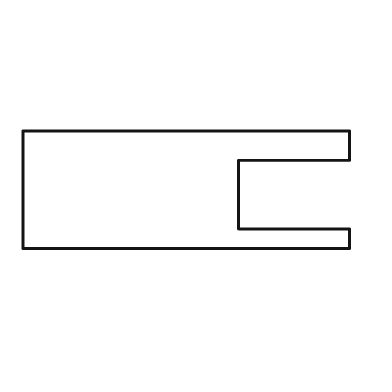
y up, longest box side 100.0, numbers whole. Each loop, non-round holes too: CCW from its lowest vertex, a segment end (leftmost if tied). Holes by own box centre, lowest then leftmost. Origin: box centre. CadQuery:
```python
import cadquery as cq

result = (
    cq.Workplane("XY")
    .moveTo(-50.0, -18.0)
    .lineTo(50.0, -18.0)
    .lineTo(50.0, -12.0)
    .lineTo(16.0, -12.0)
    .lineTo(16.0, 9.0)
    .lineTo(50.0, 9.0)
    .lineTo(50.0, 18.0)
    .lineTo(-50.0, 18.0)
    .close()
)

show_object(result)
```